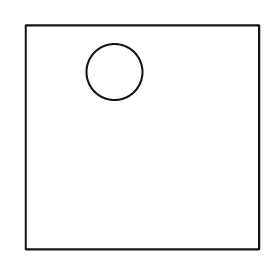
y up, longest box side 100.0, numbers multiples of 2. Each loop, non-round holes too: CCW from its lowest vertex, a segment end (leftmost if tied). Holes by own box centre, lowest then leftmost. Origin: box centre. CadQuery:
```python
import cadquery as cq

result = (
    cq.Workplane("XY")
    .moveTo(-50.0, -48.0)
    .lineTo(50.0, -48.0)
    .lineTo(50.0, 48.0)
    .lineTo(-50.0, 48.0)
    .close()
    .moveTo(-12.0, 28.0)
    .circle(12.0)
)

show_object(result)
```